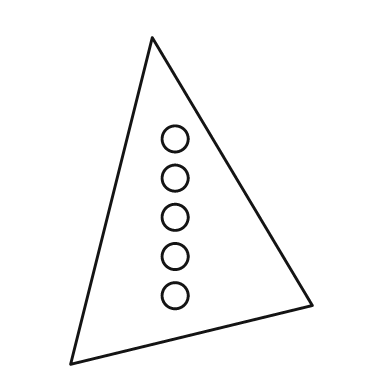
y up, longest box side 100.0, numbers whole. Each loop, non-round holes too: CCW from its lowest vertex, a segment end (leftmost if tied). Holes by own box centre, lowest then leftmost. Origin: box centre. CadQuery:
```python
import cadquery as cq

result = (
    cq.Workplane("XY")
    .moveTo(-37.0, -50.0)
    .lineTo(37.0, -32.0)
    .lineTo(-12.0, 50.0)
    .close()
    .moveTo(-5.0, -29.0)
    .circle(4.0)
    .moveTo(-5.0, -17.0)
    .circle(4.0)
    .moveTo(-5.0, -5.0)
    .circle(4.0)
    .moveTo(-5.0, 7.0)
    .circle(4.0)
    .moveTo(-5.0, 19.0)
    .circle(4.0)
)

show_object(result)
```